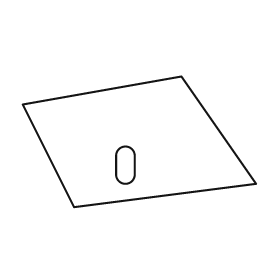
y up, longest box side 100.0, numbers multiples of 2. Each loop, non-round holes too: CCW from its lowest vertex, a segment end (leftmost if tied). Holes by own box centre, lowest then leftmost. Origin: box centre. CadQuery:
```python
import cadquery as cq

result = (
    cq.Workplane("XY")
    .moveTo(-28.0, -28.0)
    .lineTo(50.0, -18.0)
    .lineTo(18.0, 28.0)
    .lineTo(-50.0, 16.0)
    .close()
    .moveTo(-10.0, -14.0)
    .threePointArc((-6.0, -18.0), (-2.0, -14.0))
    .lineTo(-2.0, -6.0)
    .threePointArc((-6.0, -2.0), (-10.0, -6.0))
    .close()
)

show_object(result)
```